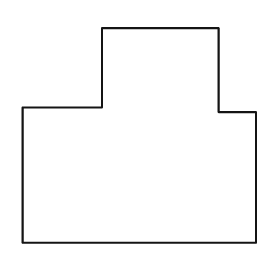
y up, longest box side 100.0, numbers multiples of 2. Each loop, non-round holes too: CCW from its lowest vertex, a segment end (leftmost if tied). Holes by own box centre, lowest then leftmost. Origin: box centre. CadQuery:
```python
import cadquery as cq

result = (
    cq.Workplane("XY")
    .moveTo(-50.0, -46.0)
    .lineTo(50.0, -46.0)
    .lineTo(50.0, 10.0)
    .lineTo(34.0, 10.0)
    .lineTo(34.0, 46.0)
    .lineTo(-16.0, 46.0)
    .lineTo(-16.0, 12.0)
    .lineTo(-50.0, 12.0)
    .close()
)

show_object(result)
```